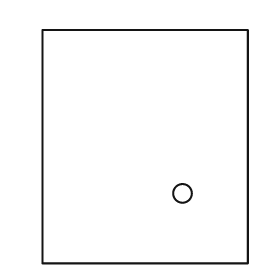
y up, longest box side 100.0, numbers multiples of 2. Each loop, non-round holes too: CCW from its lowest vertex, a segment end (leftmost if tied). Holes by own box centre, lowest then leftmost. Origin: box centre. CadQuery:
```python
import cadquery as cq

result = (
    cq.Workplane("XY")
    .moveTo(-44.0, -50.0)
    .lineTo(44.0, -50.0)
    .lineTo(44.0, 50.0)
    .lineTo(-44.0, 50.0)
    .close()
    .moveTo(16.0, -20.0)
    .circle(4.0)
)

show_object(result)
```